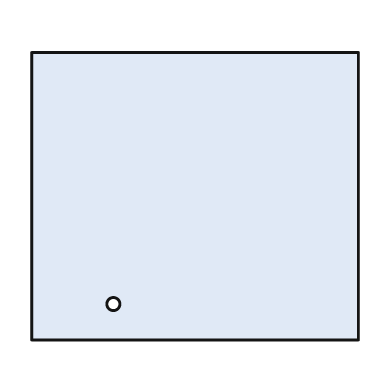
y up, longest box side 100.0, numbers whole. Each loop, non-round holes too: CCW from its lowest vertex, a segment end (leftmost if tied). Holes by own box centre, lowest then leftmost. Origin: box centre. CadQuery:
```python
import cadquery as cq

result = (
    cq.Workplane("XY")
    .moveTo(-50.0, -44.0)
    .lineTo(50.0, -44.0)
    .lineTo(50.0, 44.0)
    .lineTo(-50.0, 44.0)
    .close()
    .moveTo(-25.0, -33.0)
    .circle(2.0)
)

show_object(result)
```